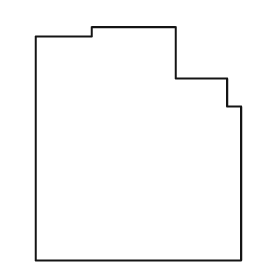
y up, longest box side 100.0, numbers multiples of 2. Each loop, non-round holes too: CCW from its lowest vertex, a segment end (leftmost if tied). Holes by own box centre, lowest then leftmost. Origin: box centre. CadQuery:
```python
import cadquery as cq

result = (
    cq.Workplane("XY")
    .moveTo(-44.0, -50.0)
    .lineTo(44.0, -50.0)
    .lineTo(44.0, 16.0)
    .lineTo(38.0, 16.0)
    .lineTo(38.0, 28.0)
    .lineTo(16.0, 28.0)
    .lineTo(16.0, 50.0)
    .lineTo(-20.0, 50.0)
    .lineTo(-20.0, 46.0)
    .lineTo(-44.0, 46.0)
    .close()
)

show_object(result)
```